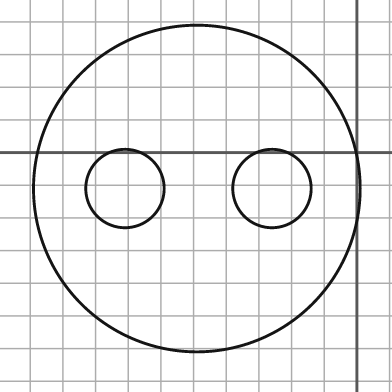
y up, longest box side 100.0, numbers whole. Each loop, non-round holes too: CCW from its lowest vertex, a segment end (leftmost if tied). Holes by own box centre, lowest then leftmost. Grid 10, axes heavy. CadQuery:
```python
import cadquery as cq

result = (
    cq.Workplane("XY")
    .moveTo(-49.0, -11.0)
    .circle(50.0)
    .moveTo(-71.0, -11.0)
    .circle(12.0)
    .moveTo(-26.0, -11.0)
    .circle(12.0)
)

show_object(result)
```